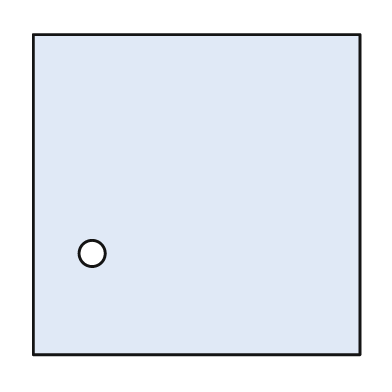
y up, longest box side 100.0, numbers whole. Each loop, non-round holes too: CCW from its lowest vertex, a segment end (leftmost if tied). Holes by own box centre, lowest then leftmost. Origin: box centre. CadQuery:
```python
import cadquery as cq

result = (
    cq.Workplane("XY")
    .moveTo(-50.0, -49.0)
    .lineTo(50.0, -49.0)
    .lineTo(50.0, 49.0)
    .lineTo(-50.0, 49.0)
    .close()
    .moveTo(-32.0, -18.0)
    .circle(4.0)
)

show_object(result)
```